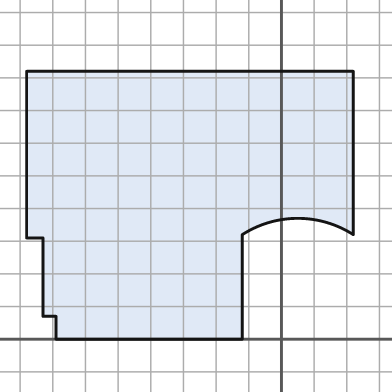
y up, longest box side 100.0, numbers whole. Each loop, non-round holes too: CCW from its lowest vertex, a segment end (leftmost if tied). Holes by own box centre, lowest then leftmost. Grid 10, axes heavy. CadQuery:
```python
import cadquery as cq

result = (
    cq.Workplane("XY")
    .moveTo(-69.0, 0.0)
    .lineTo(-12.0, 0.0)
    .lineTo(-12.0, 32.0)
    .threePointArc((5.0, 37.0), (22.0, 32.0))
    .lineTo(22.0, 82.0)
    .lineTo(-78.0, 82.0)
    .lineTo(-78.0, 31.0)
    .lineTo(-73.0, 31.0)
    .lineTo(-73.0, 7.0)
    .lineTo(-69.0, 7.0)
    .close()
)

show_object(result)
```